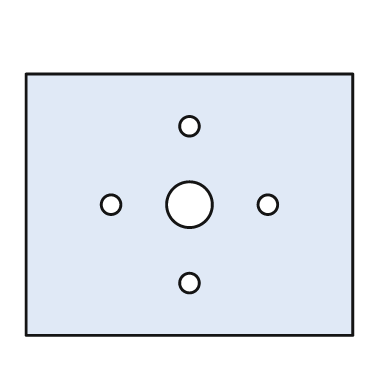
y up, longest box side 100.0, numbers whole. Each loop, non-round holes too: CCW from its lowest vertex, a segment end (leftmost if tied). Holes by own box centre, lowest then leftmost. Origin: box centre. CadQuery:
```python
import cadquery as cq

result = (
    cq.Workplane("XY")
    .moveTo(-50.0, -40.0)
    .lineTo(50.0, -40.0)
    .lineTo(50.0, 40.0)
    .lineTo(-50.0, 40.0)
    .close()
    .moveTo(0.0, -24.0)
    .circle(3.0)
    .moveTo(-24.0, 0.0)
    .circle(3.0)
    .moveTo(0.0, 0.0)
    .circle(7.0)
    .moveTo(24.0, 0.0)
    .circle(3.0)
    .moveTo(0.0, 24.0)
    .circle(3.0)
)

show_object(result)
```